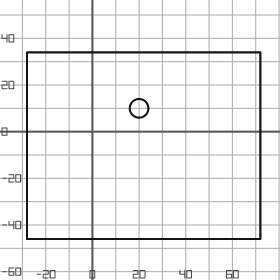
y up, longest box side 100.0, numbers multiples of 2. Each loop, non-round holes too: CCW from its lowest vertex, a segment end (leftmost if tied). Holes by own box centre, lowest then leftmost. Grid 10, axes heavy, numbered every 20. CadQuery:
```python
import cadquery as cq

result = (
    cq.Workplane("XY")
    .moveTo(-28.0, -46.0)
    .lineTo(72.0, -46.0)
    .lineTo(72.0, 34.0)
    .lineTo(-28.0, 34.0)
    .close()
    .moveTo(20.0, 10.0)
    .circle(4.0)
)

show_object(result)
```